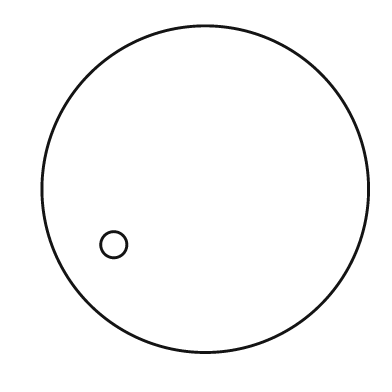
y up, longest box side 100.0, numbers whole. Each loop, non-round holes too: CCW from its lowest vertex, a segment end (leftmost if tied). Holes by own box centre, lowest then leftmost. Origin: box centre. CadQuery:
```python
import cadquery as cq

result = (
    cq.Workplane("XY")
    .moveTo(0.0, 0.0)
    .circle(50.0)
    .moveTo(-28.0, -17.0)
    .circle(4.0)
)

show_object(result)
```